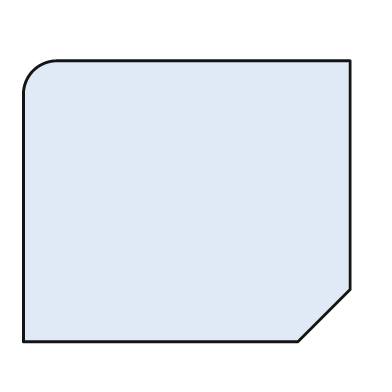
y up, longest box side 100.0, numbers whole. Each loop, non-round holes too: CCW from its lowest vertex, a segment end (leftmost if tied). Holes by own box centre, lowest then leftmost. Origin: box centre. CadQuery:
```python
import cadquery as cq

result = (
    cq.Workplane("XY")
    .moveTo(-50.0, -43.0)
    .lineTo(34.0, -43.0)
    .lineTo(50.0, -27.0)
    .lineTo(50.0, 43.0)
    .lineTo(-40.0, 43.0)
    .threePointArc((-47.0, 40.0), (-50.0, 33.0))
    .close()
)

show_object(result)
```